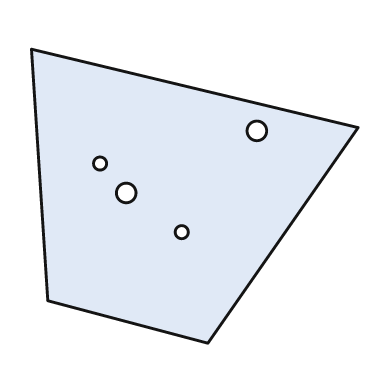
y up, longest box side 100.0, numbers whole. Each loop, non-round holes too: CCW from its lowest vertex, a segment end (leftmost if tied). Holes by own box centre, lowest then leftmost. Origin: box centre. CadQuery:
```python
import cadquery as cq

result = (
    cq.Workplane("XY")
    .moveTo(4.0, -45.0)
    .lineTo(50.0, 21.0)
    .lineTo(-50.0, 45.0)
    .lineTo(-45.0, -32.0)
    .close()
    .moveTo(-4.0, -11.0)
    .circle(2.0)
    .moveTo(-21.0, 1.0)
    .circle(3.0)
    .moveTo(-29.0, 10.0)
    .circle(2.0)
    .moveTo(19.0, 20.0)
    .circle(3.0)
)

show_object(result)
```